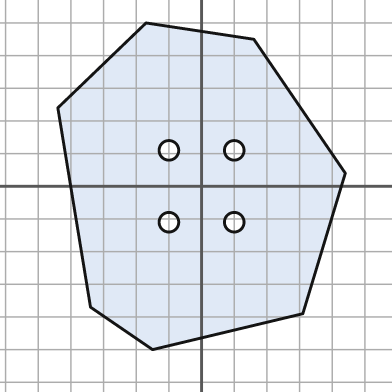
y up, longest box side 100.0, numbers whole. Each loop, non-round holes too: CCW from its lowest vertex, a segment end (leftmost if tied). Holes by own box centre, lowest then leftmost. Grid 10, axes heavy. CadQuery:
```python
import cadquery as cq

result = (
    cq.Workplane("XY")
    .moveTo(-15.0, -50.0)
    .lineTo(31.0, -39.0)
    .lineTo(44.0, 4.0)
    .lineTo(16.0, 45.0)
    .lineTo(-17.0, 50.0)
    .lineTo(-44.0, 24.0)
    .lineTo(-34.0, -37.0)
    .close()
    .moveTo(-10.0, -11.0)
    .circle(3.0)
    .moveTo(10.0, -11.0)
    .circle(3.0)
    .moveTo(-10.0, 11.0)
    .circle(3.0)
    .moveTo(10.0, 11.0)
    .circle(3.0)
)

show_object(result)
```